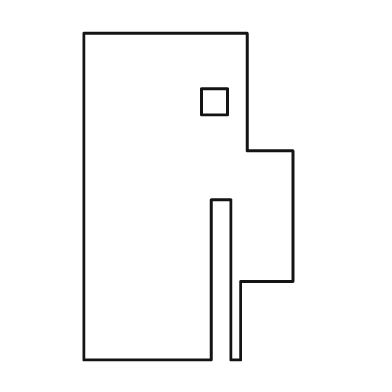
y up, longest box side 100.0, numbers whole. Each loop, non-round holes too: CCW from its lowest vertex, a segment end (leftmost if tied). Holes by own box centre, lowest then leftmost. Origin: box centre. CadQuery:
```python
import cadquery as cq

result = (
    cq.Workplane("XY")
    .moveTo(-32.0, -50.0)
    .lineTo(7.0, -50.0)
    .lineTo(7.0, -1.0)
    .lineTo(13.0, -1.0)
    .lineTo(13.0, -50.0)
    .lineTo(16.0, -50.0)
    .lineTo(16.0, -26.0)
    .lineTo(32.0, -26.0)
    .lineTo(32.0, 14.0)
    .lineTo(18.0, 14.0)
    .lineTo(18.0, 50.0)
    .lineTo(-32.0, 50.0)
    .close()
    .moveTo(4.0, 25.0)
    .lineTo(12.0, 25.0)
    .lineTo(12.0, 33.0)
    .lineTo(4.0, 33.0)
    .close()
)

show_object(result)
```